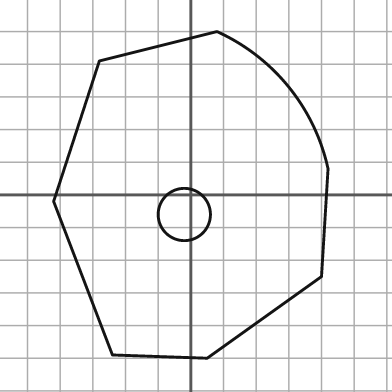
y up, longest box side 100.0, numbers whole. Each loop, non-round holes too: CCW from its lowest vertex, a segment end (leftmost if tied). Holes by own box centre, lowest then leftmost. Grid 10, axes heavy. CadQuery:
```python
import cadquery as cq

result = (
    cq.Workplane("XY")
    .moveTo(5.0, -50.0)
    .lineTo(40.0, -25.0)
    .lineTo(42.0, 8.0)
    .threePointArc((30.0, 33.0), (8.0, 50.0))
    .lineTo(-28.0, 41.0)
    .lineTo(-42.0, -2.0)
    .lineTo(-24.0, -49.0)
    .close()
    .moveTo(-2.0, -6.0)
    .circle(8.0)
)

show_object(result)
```